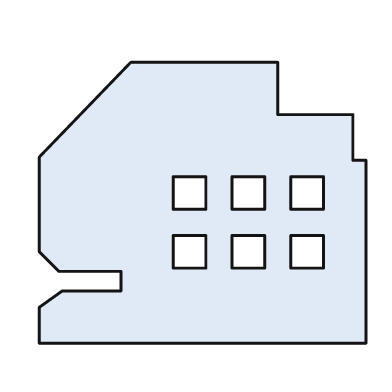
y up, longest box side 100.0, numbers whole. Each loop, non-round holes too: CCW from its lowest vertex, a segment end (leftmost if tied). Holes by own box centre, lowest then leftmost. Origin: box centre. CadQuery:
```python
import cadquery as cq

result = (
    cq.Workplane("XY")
    .moveTo(-50.0, -43.0)
    .lineTo(50.0, -43.0)
    .lineTo(50.0, 13.0)
    .lineTo(46.0, 13.0)
    .lineTo(46.0, 27.0)
    .lineTo(23.0, 27.0)
    .lineTo(23.0, 43.0)
    .lineTo(-22.0, 43.0)
    .lineTo(-50.0, 14.0)
    .lineTo(-50.0, -15.0)
    .lineTo(-44.0, -21.0)
    .lineTo(-25.0, -21.0)
    .lineTo(-25.0, -27.0)
    .lineTo(-43.0, -27.0)
    .lineTo(-50.0, -32.0)
    .close()
    .moveTo(-9.0, -20.0)
    .lineTo(1.0, -20.0)
    .lineTo(1.0, -10.0)
    .lineTo(-9.0, -10.0)
    .close()
    .moveTo(9.0, -20.0)
    .lineTo(19.0, -20.0)
    .lineTo(19.0, -10.0)
    .lineTo(9.0, -10.0)
    .close()
    .moveTo(27.0, -20.0)
    .lineTo(37.0, -20.0)
    .lineTo(37.0, -10.0)
    .lineTo(27.0, -10.0)
    .close()
    .moveTo(-9.0, -2.0)
    .lineTo(1.0, -2.0)
    .lineTo(1.0, 8.0)
    .lineTo(-9.0, 8.0)
    .close()
    .moveTo(9.0, -2.0)
    .lineTo(19.0, -2.0)
    .lineTo(19.0, 8.0)
    .lineTo(9.0, 8.0)
    .close()
    .moveTo(27.0, -2.0)
    .lineTo(37.0, -2.0)
    .lineTo(37.0, 8.0)
    .lineTo(27.0, 8.0)
    .close()
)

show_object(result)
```